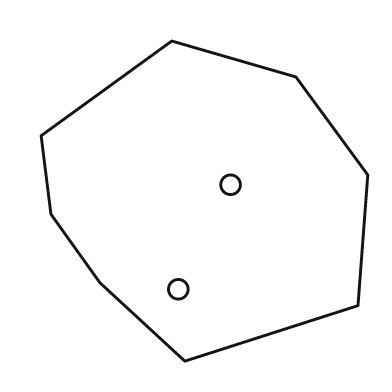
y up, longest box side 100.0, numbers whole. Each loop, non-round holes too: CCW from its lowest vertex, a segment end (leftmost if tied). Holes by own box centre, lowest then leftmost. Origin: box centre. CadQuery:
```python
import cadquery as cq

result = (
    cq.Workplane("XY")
    .moveTo(-6.0, -49.0)
    .lineTo(47.0, -32.0)
    .lineTo(50.0, 8.0)
    .lineTo(28.0, 38.0)
    .lineTo(-10.0, 49.0)
    .lineTo(-50.0, 20.0)
    .lineTo(-47.0, -4.0)
    .lineTo(-32.0, -25.0)
    .close()
    .moveTo(-8.0, -27.0)
    .circle(3.0)
    .moveTo(8.0, 5.0)
    .circle(3.0)
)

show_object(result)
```